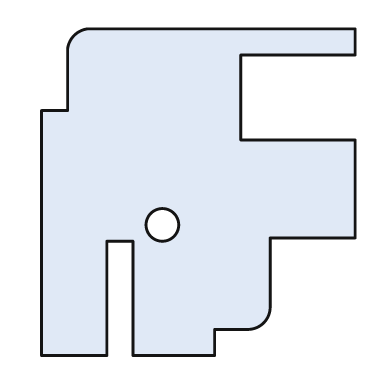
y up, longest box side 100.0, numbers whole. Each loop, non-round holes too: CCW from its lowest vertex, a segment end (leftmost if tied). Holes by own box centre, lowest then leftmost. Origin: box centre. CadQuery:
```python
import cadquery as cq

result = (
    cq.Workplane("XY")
    .moveTo(-48.0, -50.0)
    .lineTo(-28.0, -50.0)
    .lineTo(-28.0, -15.0)
    .lineTo(-20.0, -15.0)
    .lineTo(-20.0, -50.0)
    .lineTo(5.0, -50.0)
    .lineTo(5.0, -42.0)
    .lineTo(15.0, -42.0)
    .threePointArc((20.0, -40.0), (22.0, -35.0))
    .lineTo(22.0, -14.0)
    .lineTo(48.0, -14.0)
    .lineTo(48.0, 16.0)
    .lineTo(13.0, 16.0)
    .lineTo(13.0, 42.0)
    .lineTo(48.0, 42.0)
    .lineTo(48.0, 50.0)
    .lineTo(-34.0, 50.0)
    .threePointArc((-38.0, 48.0), (-40.0, 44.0))
    .lineTo(-40.0, 25.0)
    .lineTo(-48.0, 25.0)
    .close()
    .moveTo(-11.0, -10.0)
    .circle(5.0)
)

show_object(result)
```